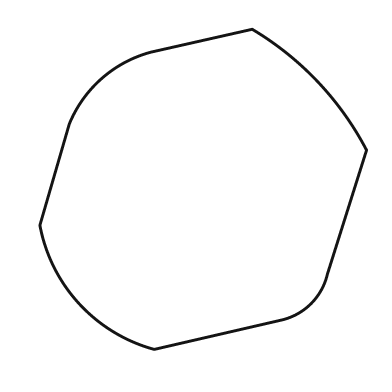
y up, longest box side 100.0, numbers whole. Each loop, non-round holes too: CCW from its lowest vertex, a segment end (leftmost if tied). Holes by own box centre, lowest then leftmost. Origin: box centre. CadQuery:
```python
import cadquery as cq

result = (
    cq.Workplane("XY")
    .moveTo(-15.0, -49.0)
    .lineTo(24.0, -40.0)
    .threePointArc((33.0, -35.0), (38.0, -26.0))
    .lineTo(50.0, 12.0)
    .threePointArc((35.0, 33.0), (15.0, 49.0))
    .lineTo(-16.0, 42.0)
    .threePointArc((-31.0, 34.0), (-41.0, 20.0))
    .lineTo(-50.0, -11.0)
    .threePointArc((-38.0, -35.0), (-15.0, -49.0))
    .close()
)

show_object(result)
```